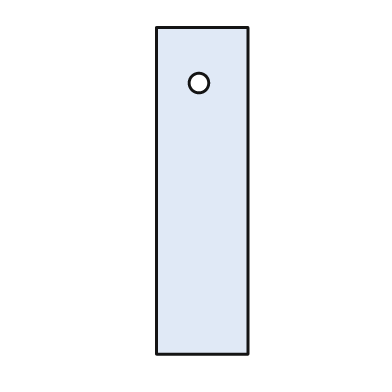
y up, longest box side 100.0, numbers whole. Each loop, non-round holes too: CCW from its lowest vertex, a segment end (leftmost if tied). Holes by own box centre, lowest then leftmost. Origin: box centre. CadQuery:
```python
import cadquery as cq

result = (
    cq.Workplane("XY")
    .moveTo(-14.0, -50.0)
    .lineTo(14.0, -50.0)
    .lineTo(14.0, 50.0)
    .lineTo(-14.0, 50.0)
    .close()
    .moveTo(-1.0, 33.0)
    .circle(3.0)
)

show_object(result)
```